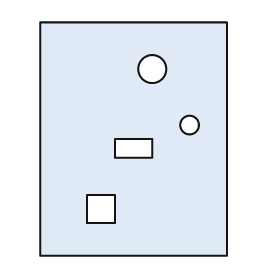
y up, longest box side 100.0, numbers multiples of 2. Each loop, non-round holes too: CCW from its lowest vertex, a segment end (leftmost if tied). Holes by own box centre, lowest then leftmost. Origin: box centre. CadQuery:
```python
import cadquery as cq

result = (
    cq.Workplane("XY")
    .moveTo(-40.0, -50.0)
    .lineTo(40.0, -50.0)
    .lineTo(40.0, 50.0)
    .lineTo(-40.0, 50.0)
    .close()
    .moveTo(-20.0, -36.0)
    .lineTo(-8.0, -36.0)
    .lineTo(-8.0, -24.0)
    .lineTo(-20.0, -24.0)
    .close()
    .moveTo(-8.0, -8.0)
    .lineTo(8.0, -8.0)
    .lineTo(8.0, 0.0)
    .lineTo(-8.0, 0.0)
    .close()
    .moveTo(24.0, 6.0)
    .circle(4.0)
    .moveTo(8.0, 30.0)
    .circle(6.0)
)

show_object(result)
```